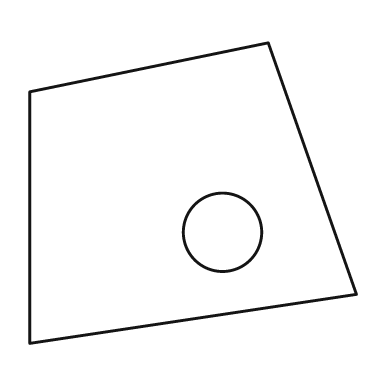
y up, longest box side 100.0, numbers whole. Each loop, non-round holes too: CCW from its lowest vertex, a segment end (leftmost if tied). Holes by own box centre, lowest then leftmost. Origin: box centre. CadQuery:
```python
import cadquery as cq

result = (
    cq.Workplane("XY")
    .moveTo(-50.0, -46.0)
    .lineTo(50.0, -31.0)
    .lineTo(23.0, 46.0)
    .lineTo(-50.0, 31.0)
    .close()
    .moveTo(9.0, -12.0)
    .circle(12.0)
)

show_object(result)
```